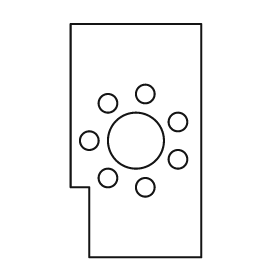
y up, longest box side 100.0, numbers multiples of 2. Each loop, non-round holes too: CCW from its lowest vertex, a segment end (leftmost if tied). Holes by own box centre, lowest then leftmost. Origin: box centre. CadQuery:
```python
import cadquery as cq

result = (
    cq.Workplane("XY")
    .moveTo(-20.0, -50.0)
    .lineTo(28.0, -50.0)
    .lineTo(28.0, 50.0)
    .lineTo(-28.0, 50.0)
    .lineTo(-28.0, -20.0)
    .lineTo(-20.0, -20.0)
    .close()
    .moveTo(4.0, -20.0)
    .circle(4.0)
    .moveTo(-12.0, -16.0)
    .circle(4.0)
    .moveTo(18.0, -8.0)
    .circle(4.0)
    .moveTo(-20.0, 0.0)
    .circle(4.0)
    .moveTo(0.0, 0.0)
    .circle(12.0)
    .moveTo(18.0, 8.0)
    .circle(4.0)
    .moveTo(-12.0, 16.0)
    .circle(4.0)
    .moveTo(4.0, 20.0)
    .circle(4.0)
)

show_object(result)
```